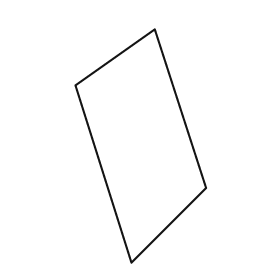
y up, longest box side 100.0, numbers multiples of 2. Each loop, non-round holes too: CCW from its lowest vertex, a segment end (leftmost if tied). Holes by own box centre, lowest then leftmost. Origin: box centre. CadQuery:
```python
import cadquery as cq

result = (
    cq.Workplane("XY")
    .moveTo(-4.0, -50.0)
    .lineTo(28.0, -18.0)
    .lineTo(6.0, 50.0)
    .lineTo(-28.0, 26.0)
    .close()
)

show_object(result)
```